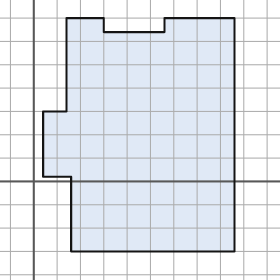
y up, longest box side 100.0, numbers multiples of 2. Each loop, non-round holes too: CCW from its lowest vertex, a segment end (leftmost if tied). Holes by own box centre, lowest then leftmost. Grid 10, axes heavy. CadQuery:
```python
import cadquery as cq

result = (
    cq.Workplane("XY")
    .moveTo(16.0, -30.0)
    .lineTo(86.0, -30.0)
    .lineTo(86.0, 70.0)
    .lineTo(56.0, 70.0)
    .lineTo(56.0, 64.0)
    .lineTo(30.0, 64.0)
    .lineTo(30.0, 70.0)
    .lineTo(14.0, 70.0)
    .lineTo(14.0, 30.0)
    .lineTo(4.0, 30.0)
    .lineTo(4.0, 2.0)
    .lineTo(16.0, 2.0)
    .close()
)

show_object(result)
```